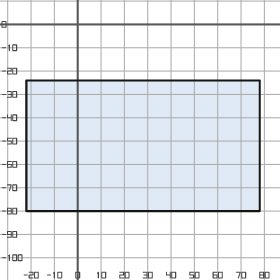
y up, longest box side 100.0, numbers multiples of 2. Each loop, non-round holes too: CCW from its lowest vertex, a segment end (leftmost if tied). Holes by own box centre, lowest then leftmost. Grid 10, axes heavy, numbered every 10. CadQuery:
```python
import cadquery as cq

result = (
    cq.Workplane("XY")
    .moveTo(-22.0, -80.0)
    .lineTo(78.0, -80.0)
    .lineTo(78.0, -24.0)
    .lineTo(-22.0, -24.0)
    .close()
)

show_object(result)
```